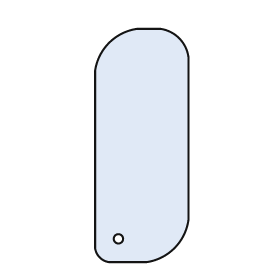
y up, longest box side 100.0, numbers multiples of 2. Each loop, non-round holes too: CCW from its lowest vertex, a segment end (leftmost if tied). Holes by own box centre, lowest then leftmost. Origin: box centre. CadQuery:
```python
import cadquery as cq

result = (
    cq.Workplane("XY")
    .moveTo(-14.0, -50.0)
    .lineTo(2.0, -50.0)
    .threePointArc((14.0, -44.0), (20.0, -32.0))
    .lineTo(20.0, 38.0)
    .threePointArc((16.0, 46.0), (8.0, 50.0))
    .lineTo(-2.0, 50.0)
    .threePointArc((-14.0, 44.0), (-20.0, 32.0))
    .lineTo(-20.0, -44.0)
    .threePointArc((-18.0, -48.0), (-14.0, -50.0))
    .close()
    .moveTo(-10.0, -40.0)
    .circle(2.0)
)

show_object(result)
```